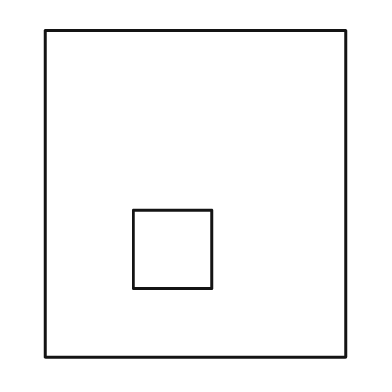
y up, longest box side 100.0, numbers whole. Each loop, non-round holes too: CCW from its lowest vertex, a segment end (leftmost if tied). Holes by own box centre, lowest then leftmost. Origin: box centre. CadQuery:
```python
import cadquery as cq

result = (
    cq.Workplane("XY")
    .moveTo(-46.0, -50.0)
    .lineTo(46.0, -50.0)
    .lineTo(46.0, 50.0)
    .lineTo(-46.0, 50.0)
    .close()
    .moveTo(-19.0, -29.0)
    .lineTo(5.0, -29.0)
    .lineTo(5.0, -5.0)
    .lineTo(-19.0, -5.0)
    .close()
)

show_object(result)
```